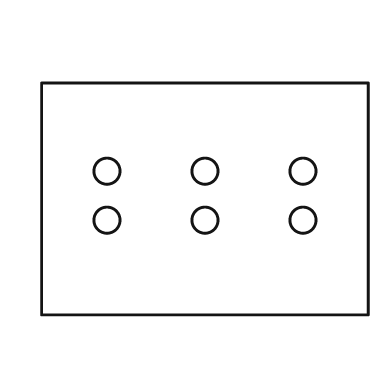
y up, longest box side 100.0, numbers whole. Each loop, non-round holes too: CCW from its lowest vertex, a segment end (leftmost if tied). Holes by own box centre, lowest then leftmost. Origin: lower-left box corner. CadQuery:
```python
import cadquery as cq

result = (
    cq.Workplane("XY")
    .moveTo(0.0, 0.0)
    .lineTo(100.0, 0.0)
    .lineTo(100.0, 71.0)
    .lineTo(0.0, 71.0)
    .close()
    .moveTo(20.0, 29.0)
    .circle(4.0)
    .moveTo(50.0, 29.0)
    .circle(4.0)
    .moveTo(80.0, 29.0)
    .circle(4.0)
    .moveTo(20.0, 44.0)
    .circle(4.0)
    .moveTo(50.0, 44.0)
    .circle(4.0)
    .moveTo(80.0, 44.0)
    .circle(4.0)
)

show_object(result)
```